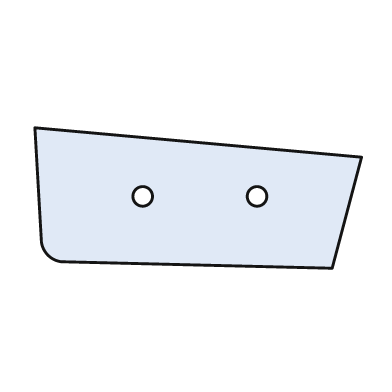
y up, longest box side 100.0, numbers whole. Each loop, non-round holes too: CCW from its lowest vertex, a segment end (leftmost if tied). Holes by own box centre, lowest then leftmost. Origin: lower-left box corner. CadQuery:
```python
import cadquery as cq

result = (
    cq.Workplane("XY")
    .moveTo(91.0, 0.0)
    .lineTo(100.0, 34.0)
    .lineTo(0.0, 43.0)
    .lineTo(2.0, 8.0)
    .threePointArc((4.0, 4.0), (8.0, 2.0))
    .close()
    .moveTo(33.0, 22.0)
    .circle(3.0)
    .moveTo(68.0, 22.0)
    .circle(3.0)
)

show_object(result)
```